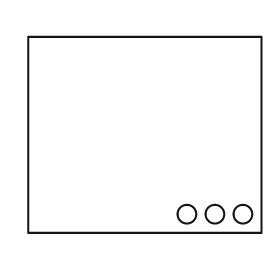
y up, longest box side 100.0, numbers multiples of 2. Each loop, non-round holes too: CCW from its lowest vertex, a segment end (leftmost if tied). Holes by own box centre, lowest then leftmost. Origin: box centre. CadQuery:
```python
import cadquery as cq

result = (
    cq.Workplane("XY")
    .moveTo(-50.0, -42.0)
    .lineTo(50.0, -42.0)
    .lineTo(50.0, 42.0)
    .lineTo(-50.0, 42.0)
    .close()
    .moveTo(18.0, -34.0)
    .circle(4.0)
    .moveTo(30.0, -34.0)
    .circle(4.0)
    .moveTo(42.0, -34.0)
    .circle(4.0)
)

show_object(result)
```